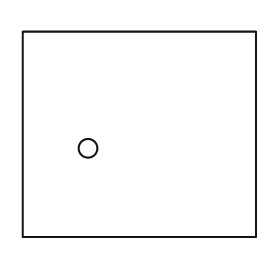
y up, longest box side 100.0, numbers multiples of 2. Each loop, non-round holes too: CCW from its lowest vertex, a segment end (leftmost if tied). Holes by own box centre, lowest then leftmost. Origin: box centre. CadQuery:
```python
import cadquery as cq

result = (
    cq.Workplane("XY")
    .moveTo(-50.0, -44.0)
    .lineTo(50.0, -44.0)
    .lineTo(50.0, 44.0)
    .lineTo(-50.0, 44.0)
    .close()
    .moveTo(-22.0, -6.0)
    .circle(4.0)
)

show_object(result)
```